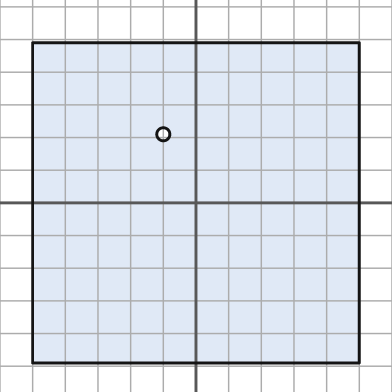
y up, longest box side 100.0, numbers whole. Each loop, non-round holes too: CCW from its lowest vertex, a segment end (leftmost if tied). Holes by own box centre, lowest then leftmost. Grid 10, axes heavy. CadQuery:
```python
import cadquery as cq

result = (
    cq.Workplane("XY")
    .moveTo(-50.0, -49.0)
    .lineTo(50.0, -49.0)
    .lineTo(50.0, 49.0)
    .lineTo(-50.0, 49.0)
    .close()
    .moveTo(-10.0, 21.0)
    .circle(2.0)
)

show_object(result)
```